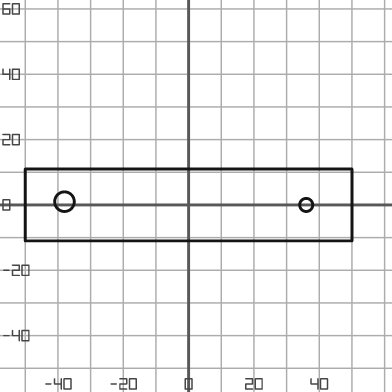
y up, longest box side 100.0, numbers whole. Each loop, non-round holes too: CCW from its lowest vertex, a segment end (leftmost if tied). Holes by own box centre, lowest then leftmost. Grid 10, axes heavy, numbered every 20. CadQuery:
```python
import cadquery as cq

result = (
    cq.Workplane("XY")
    .moveTo(-50.0, -11.0)
    .lineTo(50.0, -11.0)
    .lineTo(50.0, 11.0)
    .lineTo(-50.0, 11.0)
    .close()
    .moveTo(36.0, 0.0)
    .circle(2.0)
    .moveTo(-38.0, 1.0)
    .circle(3.0)
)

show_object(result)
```